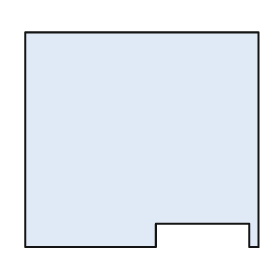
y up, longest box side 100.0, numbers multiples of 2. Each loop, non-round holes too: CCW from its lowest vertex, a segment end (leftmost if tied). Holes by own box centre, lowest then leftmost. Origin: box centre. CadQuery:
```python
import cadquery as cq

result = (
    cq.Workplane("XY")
    .moveTo(-50.0, -46.0)
    .lineTo(6.0, -46.0)
    .lineTo(6.0, -36.0)
    .lineTo(46.0, -36.0)
    .lineTo(46.0, -46.0)
    .lineTo(50.0, -46.0)
    .lineTo(50.0, 46.0)
    .lineTo(-50.0, 46.0)
    .close()
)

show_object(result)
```